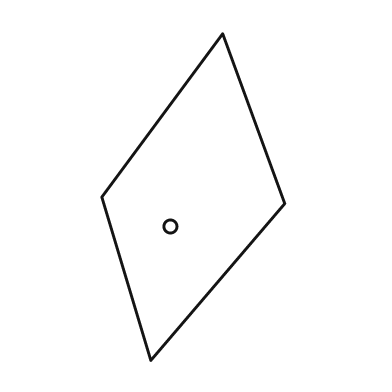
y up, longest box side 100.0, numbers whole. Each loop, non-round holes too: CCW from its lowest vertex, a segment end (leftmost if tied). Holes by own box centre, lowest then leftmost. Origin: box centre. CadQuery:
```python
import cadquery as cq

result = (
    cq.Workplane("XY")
    .moveTo(-13.0, -50.0)
    .lineTo(28.0, -2.0)
    .lineTo(9.0, 50.0)
    .lineTo(-28.0, 0.0)
    .close()
    .moveTo(-7.0, -9.0)
    .circle(2.0)
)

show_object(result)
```